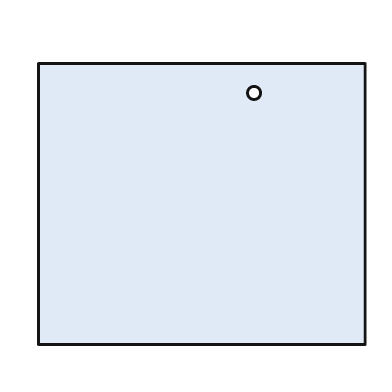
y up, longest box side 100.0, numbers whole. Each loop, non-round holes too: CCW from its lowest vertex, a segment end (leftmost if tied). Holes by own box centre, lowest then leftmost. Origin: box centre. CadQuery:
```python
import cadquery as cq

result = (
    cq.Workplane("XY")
    .moveTo(-50.0, -43.0)
    .lineTo(50.0, -43.0)
    .lineTo(50.0, 43.0)
    .lineTo(-50.0, 43.0)
    .close()
    .moveTo(16.0, 34.0)
    .circle(2.0)
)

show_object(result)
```